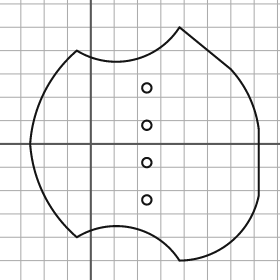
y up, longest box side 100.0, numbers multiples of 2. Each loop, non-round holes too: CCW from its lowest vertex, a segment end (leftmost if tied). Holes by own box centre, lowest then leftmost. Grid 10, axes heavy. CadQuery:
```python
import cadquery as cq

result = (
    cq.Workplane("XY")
    .moveTo(38.0, -50.0)
    .threePointArc((60.0, -42.0), (72.0, -22.0))
    .lineTo(72.0, 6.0)
    .threePointArc((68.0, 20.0), (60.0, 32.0))
    .lineTo(38.0, 50.0)
    .threePointArc((18.0, 36.0), (-6.0, 40.0))
    .threePointArc((-20.0, 22.0), (-26.0, 0.0))
    .threePointArc((-20.0, -22.0), (-6.0, -40.0))
    .threePointArc((18.0, -36.0), (38.0, -50.0))
    .close()
    .moveTo(24.0, -24.0)
    .circle(2.0)
    .moveTo(24.0, -8.0)
    .circle(2.0)
    .moveTo(24.0, 8.0)
    .circle(2.0)
    .moveTo(24.0, 24.0)
    .circle(2.0)
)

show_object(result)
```